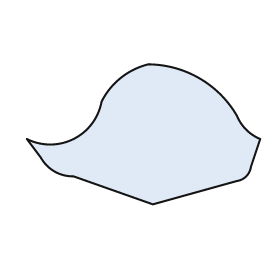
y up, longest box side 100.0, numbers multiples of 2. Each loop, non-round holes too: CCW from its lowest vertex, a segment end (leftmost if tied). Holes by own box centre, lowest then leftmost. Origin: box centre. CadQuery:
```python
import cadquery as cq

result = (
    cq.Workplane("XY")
    .moveTo(4.0, -30.0)
    .lineTo(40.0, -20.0)
    .threePointArc((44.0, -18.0), (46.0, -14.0))
    .lineTo(50.0, -2.0)
    .threePointArc((44.0, 2.0), (40.0, 8.0))
    .threePointArc((24.0, 24.0), (2.0, 30.0))
    .threePointArc((-10.0, 24.0), (-18.0, 14.0))
    .threePointArc((-30.0, -2.0), (-50.0, -2.0))
    .lineTo(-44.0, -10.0)
    .threePointArc((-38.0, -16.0), (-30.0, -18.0))
    .close()
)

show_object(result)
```